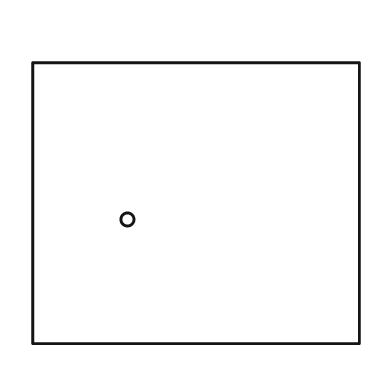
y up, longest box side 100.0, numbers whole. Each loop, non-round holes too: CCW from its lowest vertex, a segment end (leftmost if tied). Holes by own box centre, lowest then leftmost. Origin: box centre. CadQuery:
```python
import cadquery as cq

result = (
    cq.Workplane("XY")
    .moveTo(-50.0, -43.0)
    .lineTo(50.0, -43.0)
    .lineTo(50.0, 43.0)
    .lineTo(-50.0, 43.0)
    .close()
    .moveTo(-21.0, -5.0)
    .circle(2.0)
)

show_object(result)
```